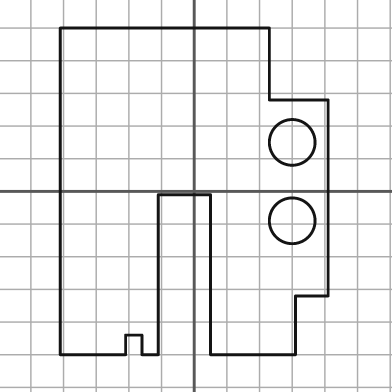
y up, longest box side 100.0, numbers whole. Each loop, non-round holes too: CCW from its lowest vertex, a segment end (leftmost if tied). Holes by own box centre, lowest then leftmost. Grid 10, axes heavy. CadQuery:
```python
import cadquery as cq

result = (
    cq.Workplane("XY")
    .moveTo(-41.0, -50.0)
    .lineTo(-21.0, -50.0)
    .lineTo(-21.0, -44.0)
    .lineTo(-16.0, -44.0)
    .lineTo(-16.0, -50.0)
    .lineTo(-11.0, -50.0)
    .lineTo(-11.0, -1.0)
    .lineTo(5.0, -1.0)
    .lineTo(5.0, -50.0)
    .lineTo(31.0, -50.0)
    .lineTo(31.0, -32.0)
    .lineTo(41.0, -32.0)
    .lineTo(41.0, 28.0)
    .lineTo(23.0, 28.0)
    .lineTo(23.0, 50.0)
    .lineTo(-41.0, 50.0)
    .close()
    .moveTo(30.0, -9.0)
    .circle(7.0)
    .moveTo(30.0, 15.0)
    .circle(7.0)
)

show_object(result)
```